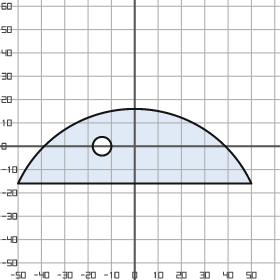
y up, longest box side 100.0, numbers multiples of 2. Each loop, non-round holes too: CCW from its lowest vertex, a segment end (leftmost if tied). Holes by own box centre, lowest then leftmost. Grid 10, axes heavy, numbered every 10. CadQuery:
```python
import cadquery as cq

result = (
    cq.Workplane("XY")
    .moveTo(-50.0, -16.0)
    .lineTo(50.0, -16.0)
    .threePointArc((0.0, 16.0), (-50.0, -16.0))
    .close()
    .moveTo(-14.0, 0.0)
    .circle(4.0)
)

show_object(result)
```